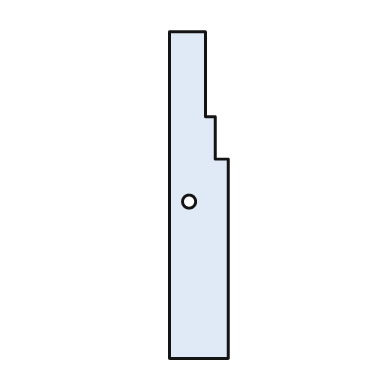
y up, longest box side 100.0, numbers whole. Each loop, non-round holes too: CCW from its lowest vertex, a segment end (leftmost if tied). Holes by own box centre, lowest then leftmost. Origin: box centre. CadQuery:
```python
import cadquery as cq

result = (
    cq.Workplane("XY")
    .moveTo(-9.0, -50.0)
    .lineTo(9.0, -50.0)
    .lineTo(9.0, 11.0)
    .lineTo(5.0, 11.0)
    .lineTo(5.0, 24.0)
    .lineTo(2.0, 24.0)
    .lineTo(2.0, 50.0)
    .lineTo(-9.0, 50.0)
    .close()
    .moveTo(-3.0, -2.0)
    .circle(2.0)
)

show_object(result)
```